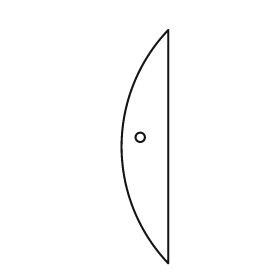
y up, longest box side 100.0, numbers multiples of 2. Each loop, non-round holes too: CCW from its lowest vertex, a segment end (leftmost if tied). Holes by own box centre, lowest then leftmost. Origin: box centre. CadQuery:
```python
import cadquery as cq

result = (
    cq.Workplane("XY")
    .moveTo(10.0, -50.0)
    .lineTo(10.0, 50.0)
    .threePointArc((-10.0, 0.0), (10.0, -50.0))
    .close()
    .moveTo(-2.0, 4.0)
    .circle(2.0)
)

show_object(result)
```